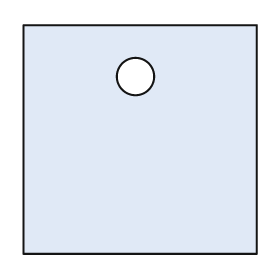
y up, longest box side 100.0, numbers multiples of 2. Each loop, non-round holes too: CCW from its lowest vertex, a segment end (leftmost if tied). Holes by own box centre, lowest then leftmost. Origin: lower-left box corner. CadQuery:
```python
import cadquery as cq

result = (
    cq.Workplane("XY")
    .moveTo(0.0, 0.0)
    .lineTo(100.0, 0.0)
    .lineTo(100.0, 98.0)
    .lineTo(0.0, 98.0)
    .close()
    .moveTo(48.0, 76.0)
    .circle(8.0)
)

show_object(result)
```